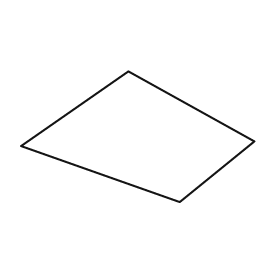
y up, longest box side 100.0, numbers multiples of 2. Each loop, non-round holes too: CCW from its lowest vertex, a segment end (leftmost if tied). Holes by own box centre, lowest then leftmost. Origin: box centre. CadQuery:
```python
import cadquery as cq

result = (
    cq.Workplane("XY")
    .moveTo(18.0, -28.0)
    .lineTo(50.0, -2.0)
    .lineTo(-4.0, 28.0)
    .lineTo(-50.0, -4.0)
    .close()
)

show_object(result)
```